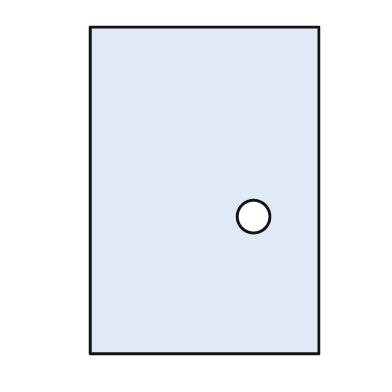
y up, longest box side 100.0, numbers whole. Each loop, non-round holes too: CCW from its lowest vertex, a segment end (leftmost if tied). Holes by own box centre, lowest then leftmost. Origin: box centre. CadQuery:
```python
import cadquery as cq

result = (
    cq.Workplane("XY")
    .moveTo(-35.0, -50.0)
    .lineTo(35.0, -50.0)
    .lineTo(35.0, 50.0)
    .lineTo(-35.0, 50.0)
    .close()
    .moveTo(15.0, -8.0)
    .circle(5.0)
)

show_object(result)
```